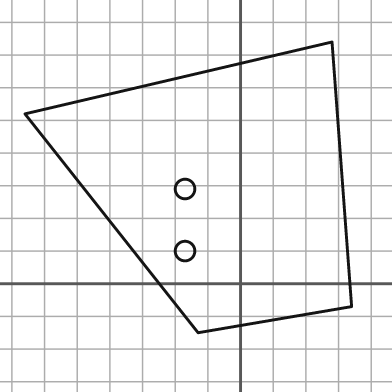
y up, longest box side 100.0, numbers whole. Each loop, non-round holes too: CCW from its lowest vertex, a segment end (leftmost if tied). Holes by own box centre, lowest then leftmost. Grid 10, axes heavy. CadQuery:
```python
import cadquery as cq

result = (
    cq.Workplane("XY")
    .moveTo(-13.0, -15.0)
    .lineTo(34.0, -7.0)
    .lineTo(28.0, 74.0)
    .lineTo(-66.0, 52.0)
    .close()
    .moveTo(-17.0, 10.0)
    .circle(3.0)
    .moveTo(-17.0, 29.0)
    .circle(3.0)
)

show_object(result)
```